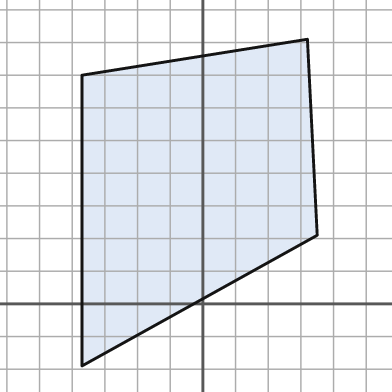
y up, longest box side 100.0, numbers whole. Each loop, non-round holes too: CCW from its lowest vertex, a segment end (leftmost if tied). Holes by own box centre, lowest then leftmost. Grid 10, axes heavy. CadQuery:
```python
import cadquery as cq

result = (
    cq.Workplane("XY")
    .moveTo(-37.0, -19.0)
    .lineTo(35.0, 21.0)
    .lineTo(32.0, 81.0)
    .lineTo(-37.0, 70.0)
    .close()
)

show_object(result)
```